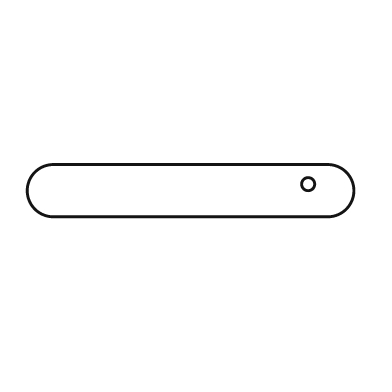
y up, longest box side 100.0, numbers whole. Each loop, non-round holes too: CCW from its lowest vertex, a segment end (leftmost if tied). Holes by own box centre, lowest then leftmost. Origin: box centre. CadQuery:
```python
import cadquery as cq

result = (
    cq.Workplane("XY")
    .moveTo(-42.0, -8.0)
    .lineTo(42.0, -8.0)
    .threePointArc((50.0, 0.0), (42.0, 8.0))
    .lineTo(-42.0, 8.0)
    .threePointArc((-50.0, 0.0), (-42.0, -8.0))
    .close()
    .moveTo(36.0, 2.0)
    .circle(2.0)
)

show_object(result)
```